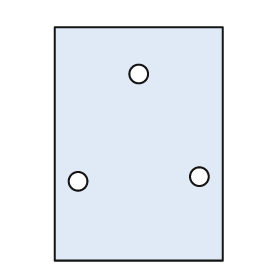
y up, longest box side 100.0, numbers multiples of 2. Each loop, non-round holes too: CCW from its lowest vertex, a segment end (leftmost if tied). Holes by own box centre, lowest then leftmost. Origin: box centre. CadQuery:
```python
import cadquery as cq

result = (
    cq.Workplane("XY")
    .moveTo(-36.0, -50.0)
    .lineTo(36.0, -50.0)
    .lineTo(36.0, 50.0)
    .lineTo(-36.0, 50.0)
    .close()
    .moveTo(-26.0, -16.0)
    .circle(4.0)
    .moveTo(26.0, -14.0)
    .circle(4.0)
    .moveTo(0.0, 30.0)
    .circle(4.0)
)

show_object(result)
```